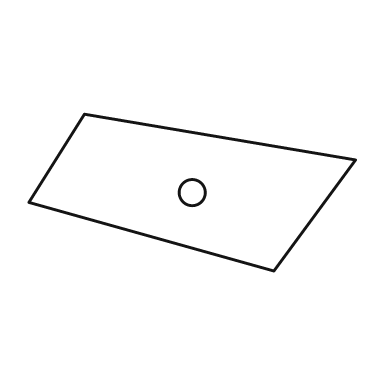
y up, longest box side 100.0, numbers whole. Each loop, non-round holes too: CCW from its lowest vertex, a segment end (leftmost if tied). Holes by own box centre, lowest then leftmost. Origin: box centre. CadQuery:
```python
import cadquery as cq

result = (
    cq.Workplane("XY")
    .moveTo(25.0, -24.0)
    .lineTo(50.0, 10.0)
    .lineTo(-33.0, 24.0)
    .lineTo(-50.0, -3.0)
    .close()
    .moveTo(0.0, 0.0)
    .circle(4.0)
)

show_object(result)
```